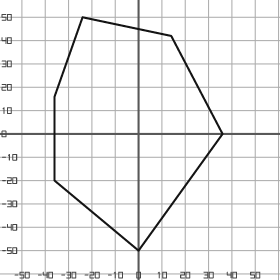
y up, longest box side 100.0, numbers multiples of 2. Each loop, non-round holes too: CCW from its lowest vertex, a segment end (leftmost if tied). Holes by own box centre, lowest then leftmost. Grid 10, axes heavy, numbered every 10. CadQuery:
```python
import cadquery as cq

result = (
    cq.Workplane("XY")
    .moveTo(0.0, -50.0)
    .lineTo(36.0, 0.0)
    .lineTo(14.0, 42.0)
    .lineTo(-24.0, 50.0)
    .lineTo(-36.0, 16.0)
    .lineTo(-36.0, -20.0)
    .close()
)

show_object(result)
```